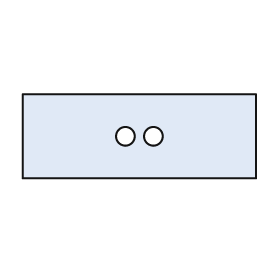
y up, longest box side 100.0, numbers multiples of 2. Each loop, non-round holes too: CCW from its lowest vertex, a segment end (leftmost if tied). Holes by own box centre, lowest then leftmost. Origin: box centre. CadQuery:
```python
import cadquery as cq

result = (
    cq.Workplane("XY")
    .moveTo(-50.0, -18.0)
    .lineTo(50.0, -18.0)
    .lineTo(50.0, 18.0)
    .lineTo(-50.0, 18.0)
    .close()
    .moveTo(-6.0, 0.0)
    .circle(4.0)
    .moveTo(6.0, 0.0)
    .circle(4.0)
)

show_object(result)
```